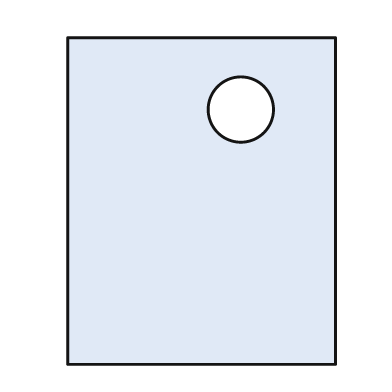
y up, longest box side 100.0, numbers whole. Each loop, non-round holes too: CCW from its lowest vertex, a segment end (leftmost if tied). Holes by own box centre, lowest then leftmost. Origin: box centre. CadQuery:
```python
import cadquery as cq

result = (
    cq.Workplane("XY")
    .moveTo(-41.0, -50.0)
    .lineTo(41.0, -50.0)
    .lineTo(41.0, 50.0)
    .lineTo(-41.0, 50.0)
    .close()
    .moveTo(12.0, 28.0)
    .circle(10.0)
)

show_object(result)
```